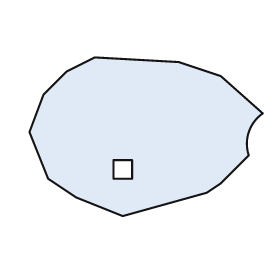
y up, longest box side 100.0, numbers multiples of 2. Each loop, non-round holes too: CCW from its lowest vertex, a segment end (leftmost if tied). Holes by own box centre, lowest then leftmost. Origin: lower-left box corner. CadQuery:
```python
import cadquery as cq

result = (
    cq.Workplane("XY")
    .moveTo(40.0, 0.0)
    .lineTo(76.0, 10.0)
    .lineTo(82.0, 14.0)
    .lineTo(94.0, 26.0)
    .threePointArc((94.0, 36.0), (100.0, 44.0))
    .lineTo(82.0, 60.0)
    .lineTo(64.0, 66.0)
    .lineTo(28.0, 68.0)
    .lineTo(16.0, 62.0)
    .lineTo(6.0, 52.0)
    .lineTo(0.0, 36.0)
    .lineTo(8.0, 16.0)
    .lineTo(20.0, 8.0)
    .close()
    .moveTo(36.0, 16.0)
    .lineTo(44.0, 16.0)
    .lineTo(44.0, 24.0)
    .lineTo(36.0, 24.0)
    .close()
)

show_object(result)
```